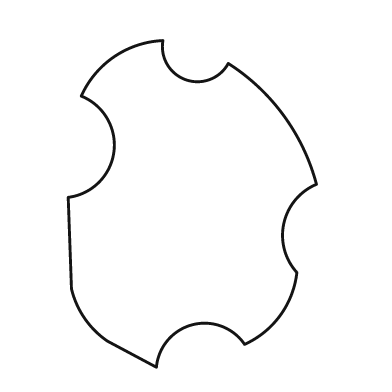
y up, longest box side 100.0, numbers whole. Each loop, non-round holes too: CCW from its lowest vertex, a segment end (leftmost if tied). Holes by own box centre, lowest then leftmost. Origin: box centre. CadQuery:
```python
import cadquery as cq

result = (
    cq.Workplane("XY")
    .moveTo(-11.0, -50.0)
    .threePointArc((0.0, -37.0), (16.0, -43.0))
    .threePointArc((27.0, -34.0), (32.0, -21.0))
    .threePointArc((28.0, -6.0), (38.0, 6.0))
    .threePointArc((28.0, 27.0), (11.0, 43.0))
    .threePointArc((-2.0, 38.0), (-9.0, 50.0))
    .threePointArc((-24.0, 45.0), (-34.0, 33.0))
    .threePointArc((-24.0, 16.0), (-38.0, 2.0))
    .lineTo(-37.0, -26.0)
    .threePointArc((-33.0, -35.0), (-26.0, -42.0))
    .close()
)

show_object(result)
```